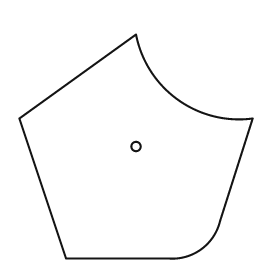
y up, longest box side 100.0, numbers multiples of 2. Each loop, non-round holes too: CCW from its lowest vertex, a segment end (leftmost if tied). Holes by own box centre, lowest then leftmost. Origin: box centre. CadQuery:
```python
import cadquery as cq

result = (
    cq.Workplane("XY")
    .moveTo(-30.0, -48.0)
    .lineTo(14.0, -48.0)
    .threePointArc((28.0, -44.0), (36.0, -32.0))
    .lineTo(50.0, 12.0)
    .threePointArc((18.0, 20.0), (0.0, 48.0))
    .lineTo(-50.0, 12.0)
    .close()
    .moveTo(0.0, 0.0)
    .circle(2.0)
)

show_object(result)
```